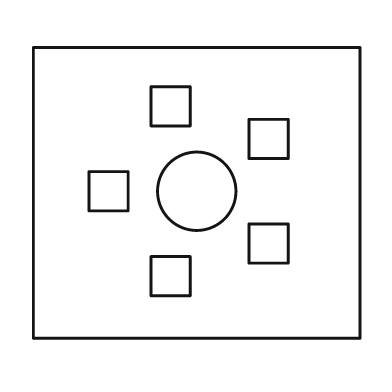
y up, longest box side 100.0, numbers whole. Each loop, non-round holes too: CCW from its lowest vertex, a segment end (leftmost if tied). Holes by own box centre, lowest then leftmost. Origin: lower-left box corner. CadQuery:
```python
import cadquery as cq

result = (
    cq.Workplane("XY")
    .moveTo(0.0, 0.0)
    .lineTo(100.0, 0.0)
    .lineTo(100.0, 89.0)
    .lineTo(0.0, 89.0)
    .close()
    .moveTo(36.0, 13.0)
    .lineTo(48.0, 13.0)
    .lineTo(48.0, 25.0)
    .lineTo(36.0, 25.0)
    .close()
    .moveTo(66.0, 23.0)
    .lineTo(78.0, 23.0)
    .lineTo(78.0, 35.0)
    .lineTo(66.0, 35.0)
    .close()
    .moveTo(17.0, 39.0)
    .lineTo(29.0, 39.0)
    .lineTo(29.0, 51.0)
    .lineTo(17.0, 51.0)
    .close()
    .moveTo(50.0, 45.0)
    .circle(12.0)
    .moveTo(66.0, 55.0)
    .lineTo(78.0, 55.0)
    .lineTo(78.0, 67.0)
    .lineTo(66.0, 67.0)
    .close()
    .moveTo(36.0, 65.0)
    .lineTo(48.0, 65.0)
    .lineTo(48.0, 77.0)
    .lineTo(36.0, 77.0)
    .close()
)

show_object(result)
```